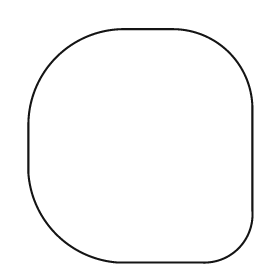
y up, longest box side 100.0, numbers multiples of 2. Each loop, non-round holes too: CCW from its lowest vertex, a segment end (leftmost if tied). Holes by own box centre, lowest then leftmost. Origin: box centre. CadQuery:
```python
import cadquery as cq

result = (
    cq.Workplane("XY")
    .moveTo(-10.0, -50.0)
    .lineTo(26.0, -50.0)
    .threePointArc((42.0, -44.0), (48.0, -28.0))
    .lineTo(48.0, 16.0)
    .threePointArc((38.0, 40.0), (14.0, 50.0))
    .lineTo(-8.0, 50.0)
    .threePointArc((-36.0, 38.0), (-48.0, 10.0))
    .lineTo(-48.0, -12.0)
    .threePointArc((-36.0, -38.0), (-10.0, -50.0))
    .close()
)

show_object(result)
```